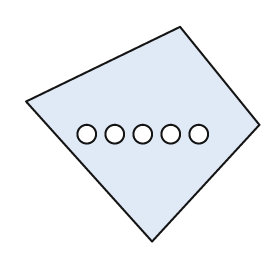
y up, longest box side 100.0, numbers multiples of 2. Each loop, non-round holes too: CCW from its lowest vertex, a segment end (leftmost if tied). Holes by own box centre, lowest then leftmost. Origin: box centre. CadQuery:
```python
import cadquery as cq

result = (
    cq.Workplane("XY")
    .moveTo(4.0, -46.0)
    .lineTo(50.0, 4.0)
    .lineTo(16.0, 46.0)
    .lineTo(-50.0, 14.0)
    .close()
    .moveTo(-24.0, 0.0)
    .circle(4.0)
    .moveTo(-12.0, 0.0)
    .circle(4.0)
    .moveTo(0.0, 0.0)
    .circle(4.0)
    .moveTo(12.0, 0.0)
    .circle(4.0)
    .moveTo(24.0, 0.0)
    .circle(4.0)
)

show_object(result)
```